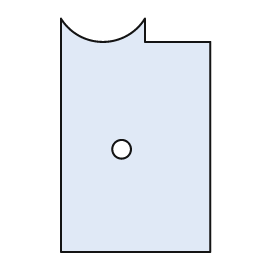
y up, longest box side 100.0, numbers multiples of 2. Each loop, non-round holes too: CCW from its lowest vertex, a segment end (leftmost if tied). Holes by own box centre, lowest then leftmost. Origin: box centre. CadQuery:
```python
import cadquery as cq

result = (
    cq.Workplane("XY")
    .moveTo(-32.0, -50.0)
    .lineTo(32.0, -50.0)
    .lineTo(32.0, 40.0)
    .lineTo(4.0, 40.0)
    .lineTo(4.0, 50.0)
    .threePointArc((-14.0, 40.0), (-32.0, 50.0))
    .close()
    .moveTo(-6.0, -6.0)
    .circle(4.0)
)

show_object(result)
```